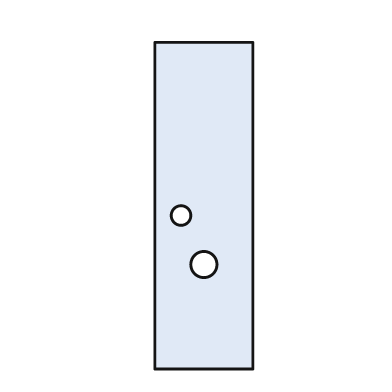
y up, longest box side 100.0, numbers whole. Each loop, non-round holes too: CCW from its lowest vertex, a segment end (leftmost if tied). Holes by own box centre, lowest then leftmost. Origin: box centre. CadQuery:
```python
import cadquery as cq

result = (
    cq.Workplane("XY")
    .moveTo(-15.0, -50.0)
    .lineTo(15.0, -50.0)
    .lineTo(15.0, 50.0)
    .lineTo(-15.0, 50.0)
    .close()
    .moveTo(0.0, -18.0)
    .circle(4.0)
    .moveTo(-7.0, -3.0)
    .circle(3.0)
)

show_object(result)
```